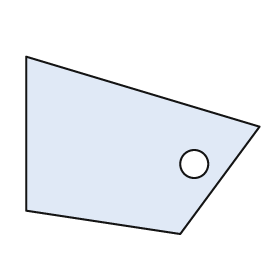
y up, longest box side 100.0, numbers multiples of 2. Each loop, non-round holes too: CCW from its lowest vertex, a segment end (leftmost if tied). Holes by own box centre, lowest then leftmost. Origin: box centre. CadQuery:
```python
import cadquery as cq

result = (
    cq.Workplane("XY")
    .moveTo(16.0, -38.0)
    .lineTo(50.0, 8.0)
    .lineTo(-50.0, 38.0)
    .lineTo(-50.0, -28.0)
    .close()
    .moveTo(22.0, -8.0)
    .circle(6.0)
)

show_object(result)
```